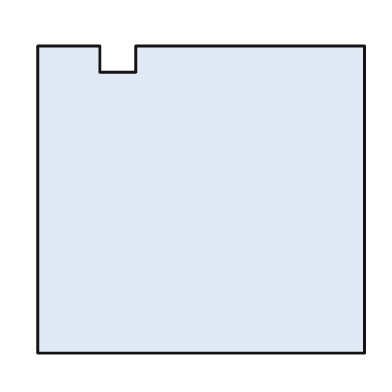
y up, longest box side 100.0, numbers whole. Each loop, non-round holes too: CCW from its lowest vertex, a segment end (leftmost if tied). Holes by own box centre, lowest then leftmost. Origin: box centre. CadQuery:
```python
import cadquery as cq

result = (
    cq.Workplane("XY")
    .moveTo(-50.0, -47.0)
    .lineTo(50.0, -47.0)
    .lineTo(50.0, 47.0)
    .lineTo(-20.0, 47.0)
    .lineTo(-20.0, 39.0)
    .lineTo(-31.0, 39.0)
    .lineTo(-31.0, 47.0)
    .lineTo(-50.0, 47.0)
    .close()
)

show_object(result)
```